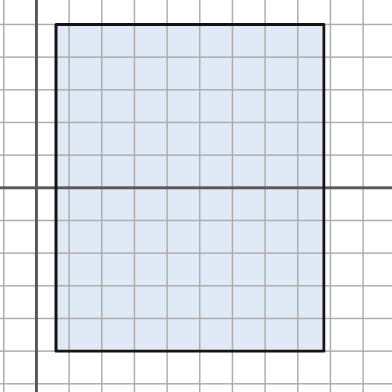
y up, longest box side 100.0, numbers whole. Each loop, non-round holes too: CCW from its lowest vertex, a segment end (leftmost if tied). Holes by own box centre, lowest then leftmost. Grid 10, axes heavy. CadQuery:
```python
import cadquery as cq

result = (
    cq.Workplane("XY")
    .moveTo(6.0, -50.0)
    .lineTo(88.0, -50.0)
    .lineTo(88.0, 50.0)
    .lineTo(6.0, 50.0)
    .close()
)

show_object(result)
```